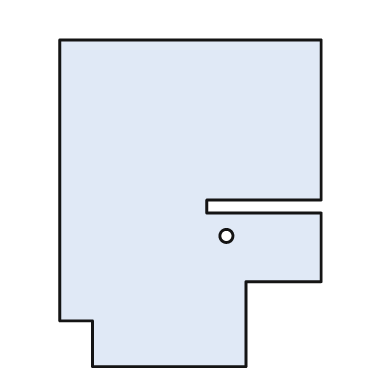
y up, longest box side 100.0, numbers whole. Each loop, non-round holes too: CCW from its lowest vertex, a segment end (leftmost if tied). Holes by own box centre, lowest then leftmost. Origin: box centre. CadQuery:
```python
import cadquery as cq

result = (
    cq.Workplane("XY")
    .moveTo(-30.0, -50.0)
    .lineTo(17.0, -50.0)
    .lineTo(17.0, -24.0)
    .lineTo(40.0, -24.0)
    .lineTo(40.0, -3.0)
    .lineTo(5.0, -3.0)
    .lineTo(5.0, 1.0)
    .lineTo(40.0, 1.0)
    .lineTo(40.0, 50.0)
    .lineTo(-40.0, 50.0)
    .lineTo(-40.0, -36.0)
    .lineTo(-30.0, -36.0)
    .close()
    .moveTo(11.0, -10.0)
    .circle(2.0)
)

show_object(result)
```